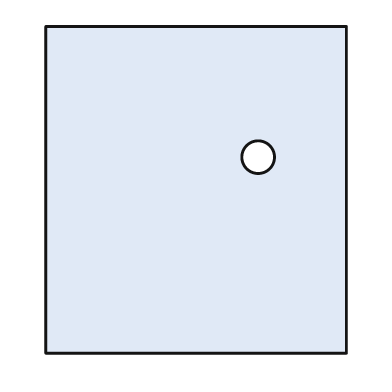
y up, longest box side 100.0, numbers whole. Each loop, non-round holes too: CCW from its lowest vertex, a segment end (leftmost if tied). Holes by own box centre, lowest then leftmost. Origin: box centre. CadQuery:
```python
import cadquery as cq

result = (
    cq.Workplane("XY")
    .moveTo(-46.0, -50.0)
    .lineTo(46.0, -50.0)
    .lineTo(46.0, 50.0)
    .lineTo(-46.0, 50.0)
    .close()
    .moveTo(19.0, 10.0)
    .circle(5.0)
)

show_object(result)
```